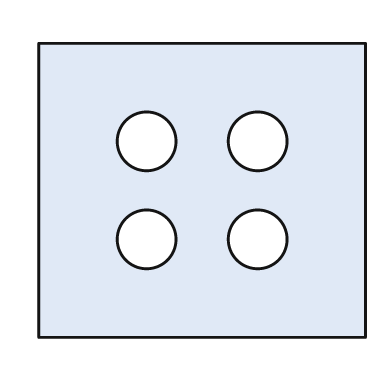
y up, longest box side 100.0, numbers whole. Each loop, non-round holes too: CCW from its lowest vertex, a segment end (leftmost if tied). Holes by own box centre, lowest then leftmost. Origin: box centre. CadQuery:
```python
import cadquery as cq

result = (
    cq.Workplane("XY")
    .moveTo(-50.0, -45.0)
    .lineTo(50.0, -45.0)
    .lineTo(50.0, 45.0)
    .lineTo(-50.0, 45.0)
    .close()
    .moveTo(-17.0, -15.0)
    .circle(9.0)
    .moveTo(17.0, -15.0)
    .circle(9.0)
    .moveTo(-17.0, 15.0)
    .circle(9.0)
    .moveTo(17.0, 15.0)
    .circle(9.0)
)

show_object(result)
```